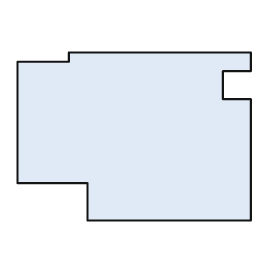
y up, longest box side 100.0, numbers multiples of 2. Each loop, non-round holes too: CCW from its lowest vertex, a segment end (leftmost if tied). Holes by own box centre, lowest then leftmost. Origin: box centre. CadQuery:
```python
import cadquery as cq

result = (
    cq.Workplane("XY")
    .moveTo(-20.0, -36.0)
    .lineTo(50.0, -36.0)
    .lineTo(50.0, 16.0)
    .lineTo(38.0, 16.0)
    .lineTo(38.0, 28.0)
    .lineTo(50.0, 28.0)
    .lineTo(50.0, 36.0)
    .lineTo(-28.0, 36.0)
    .lineTo(-28.0, 32.0)
    .lineTo(-50.0, 32.0)
    .lineTo(-50.0, -20.0)
    .lineTo(-20.0, -20.0)
    .close()
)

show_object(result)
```